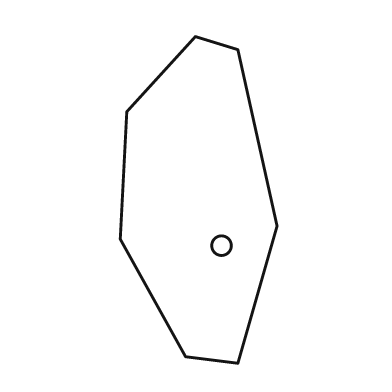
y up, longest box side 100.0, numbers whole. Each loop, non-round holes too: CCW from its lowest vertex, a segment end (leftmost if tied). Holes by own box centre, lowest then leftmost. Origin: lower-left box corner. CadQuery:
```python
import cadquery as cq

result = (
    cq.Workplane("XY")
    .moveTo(36.0, 0.0)
    .lineTo(48.0, 42.0)
    .lineTo(36.0, 96.0)
    .lineTo(23.0, 100.0)
    .lineTo(2.0, 77.0)
    .lineTo(0.0, 38.0)
    .lineTo(20.0, 2.0)
    .close()
    .moveTo(31.0, 36.0)
    .circle(3.0)
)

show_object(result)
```